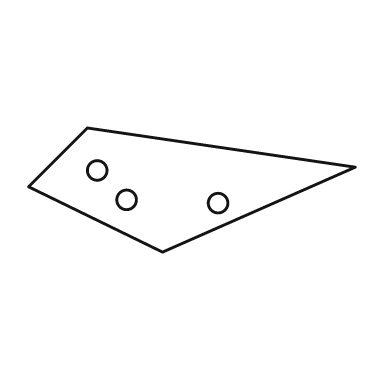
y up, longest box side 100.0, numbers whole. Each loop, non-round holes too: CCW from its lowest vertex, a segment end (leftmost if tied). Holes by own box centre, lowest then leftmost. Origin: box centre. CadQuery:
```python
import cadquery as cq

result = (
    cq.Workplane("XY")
    .moveTo(-9.0, -19.0)
    .lineTo(50.0, 7.0)
    .lineTo(-32.0, 19.0)
    .lineTo(-50.0, 1.0)
    .close()
    .moveTo(8.0, -4.0)
    .circle(3.0)
    .moveTo(-20.0, -3.0)
    .circle(3.0)
    .moveTo(-29.0, 6.0)
    .circle(3.0)
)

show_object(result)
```